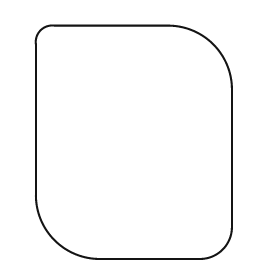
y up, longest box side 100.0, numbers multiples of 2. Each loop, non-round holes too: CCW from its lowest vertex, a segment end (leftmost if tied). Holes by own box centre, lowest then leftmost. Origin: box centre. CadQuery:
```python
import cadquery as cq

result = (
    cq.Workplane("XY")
    .moveTo(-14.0, -50.0)
    .lineTo(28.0, -50.0)
    .threePointArc((38.0, -46.0), (42.0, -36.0))
    .lineTo(42.0, 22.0)
    .threePointArc((34.0, 42.0), (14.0, 50.0))
    .lineTo(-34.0, 50.0)
    .threePointArc((-40.0, 48.0), (-42.0, 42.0))
    .lineTo(-42.0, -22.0)
    .threePointArc((-34.0, -42.0), (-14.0, -50.0))
    .close()
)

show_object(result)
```